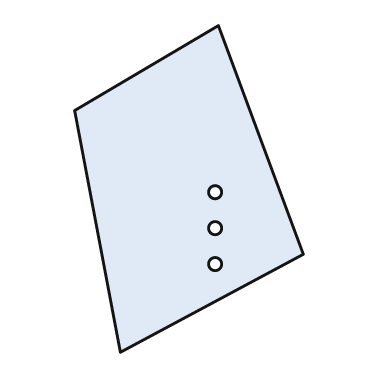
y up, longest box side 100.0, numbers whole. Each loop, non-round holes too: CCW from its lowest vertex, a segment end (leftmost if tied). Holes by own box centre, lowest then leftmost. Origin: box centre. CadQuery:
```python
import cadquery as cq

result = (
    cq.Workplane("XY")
    .moveTo(-21.0, -50.0)
    .lineTo(35.0, -20.0)
    .lineTo(9.0, 50.0)
    .lineTo(-35.0, 24.0)
    .close()
    .moveTo(8.0, -23.0)
    .circle(2.0)
    .moveTo(8.0, -12.0)
    .circle(2.0)
    .moveTo(8.0, -1.0)
    .circle(2.0)
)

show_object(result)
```